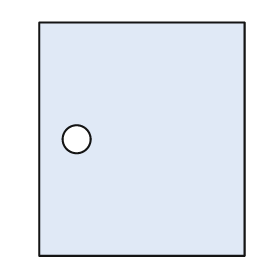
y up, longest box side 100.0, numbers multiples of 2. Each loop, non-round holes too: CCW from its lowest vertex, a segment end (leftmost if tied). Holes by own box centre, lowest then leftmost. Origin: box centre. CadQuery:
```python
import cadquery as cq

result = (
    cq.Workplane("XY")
    .moveTo(-44.0, -50.0)
    .lineTo(44.0, -50.0)
    .lineTo(44.0, 50.0)
    .lineTo(-44.0, 50.0)
    .close()
    .moveTo(-28.0, 0.0)
    .circle(6.0)
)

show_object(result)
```